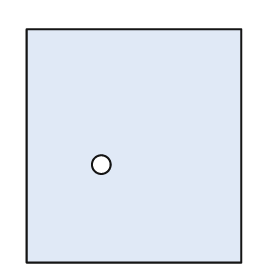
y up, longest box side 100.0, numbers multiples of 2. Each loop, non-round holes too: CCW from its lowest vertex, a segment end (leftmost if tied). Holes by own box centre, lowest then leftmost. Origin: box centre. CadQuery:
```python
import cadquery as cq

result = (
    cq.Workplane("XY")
    .moveTo(-46.0, -50.0)
    .lineTo(46.0, -50.0)
    .lineTo(46.0, 50.0)
    .lineTo(-46.0, 50.0)
    .close()
    .moveTo(-14.0, -8.0)
    .circle(4.0)
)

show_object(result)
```